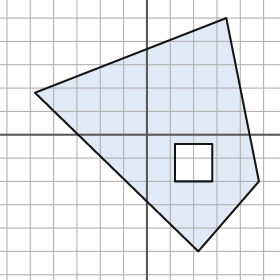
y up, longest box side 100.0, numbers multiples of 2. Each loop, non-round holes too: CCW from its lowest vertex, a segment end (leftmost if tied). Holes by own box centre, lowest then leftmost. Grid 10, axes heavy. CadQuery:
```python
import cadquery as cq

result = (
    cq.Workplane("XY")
    .moveTo(22.0, -50.0)
    .lineTo(48.0, -20.0)
    .lineTo(34.0, 50.0)
    .lineTo(-48.0, 18.0)
    .close()
    .moveTo(12.0, -20.0)
    .lineTo(28.0, -20.0)
    .lineTo(28.0, -4.0)
    .lineTo(12.0, -4.0)
    .close()
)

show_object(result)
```